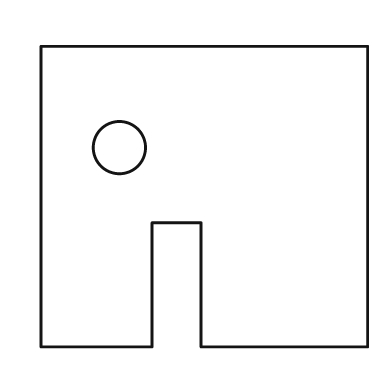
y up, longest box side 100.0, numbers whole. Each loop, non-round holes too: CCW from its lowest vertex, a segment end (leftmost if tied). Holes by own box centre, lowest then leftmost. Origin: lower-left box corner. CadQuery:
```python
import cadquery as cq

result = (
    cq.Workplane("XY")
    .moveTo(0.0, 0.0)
    .lineTo(34.0, 0.0)
    .lineTo(34.0, 38.0)
    .lineTo(49.0, 38.0)
    .lineTo(49.0, 0.0)
    .lineTo(100.0, 0.0)
    .lineTo(100.0, 92.0)
    .lineTo(0.0, 92.0)
    .close()
    .moveTo(24.0, 61.0)
    .circle(8.0)
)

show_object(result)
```